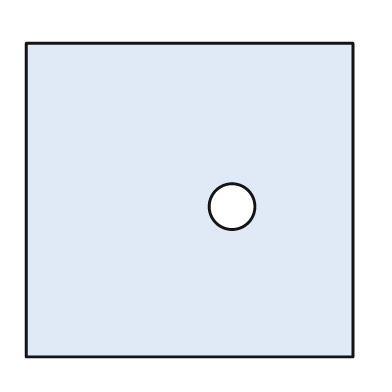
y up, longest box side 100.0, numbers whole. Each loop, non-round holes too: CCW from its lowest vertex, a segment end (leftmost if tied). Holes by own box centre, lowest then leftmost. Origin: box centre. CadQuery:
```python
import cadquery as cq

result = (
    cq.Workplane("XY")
    .moveTo(-50.0, -48.0)
    .lineTo(50.0, -48.0)
    .lineTo(50.0, 48.0)
    .lineTo(-50.0, 48.0)
    .close()
    .moveTo(13.0, -2.0)
    .circle(7.0)
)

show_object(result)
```